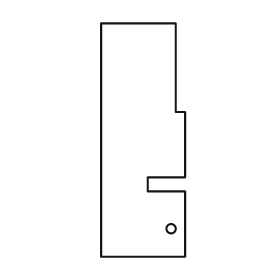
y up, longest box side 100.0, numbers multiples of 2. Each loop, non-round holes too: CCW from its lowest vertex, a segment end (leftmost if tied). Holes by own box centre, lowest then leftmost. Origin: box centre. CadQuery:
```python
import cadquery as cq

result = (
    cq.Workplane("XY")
    .moveTo(-18.0, -50.0)
    .lineTo(18.0, -50.0)
    .lineTo(18.0, -22.0)
    .lineTo(2.0, -22.0)
    .lineTo(2.0, -16.0)
    .lineTo(18.0, -16.0)
    .lineTo(18.0, 12.0)
    .lineTo(14.0, 12.0)
    .lineTo(14.0, 50.0)
    .lineTo(-18.0, 50.0)
    .close()
    .moveTo(12.0, -38.0)
    .circle(2.0)
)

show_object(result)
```